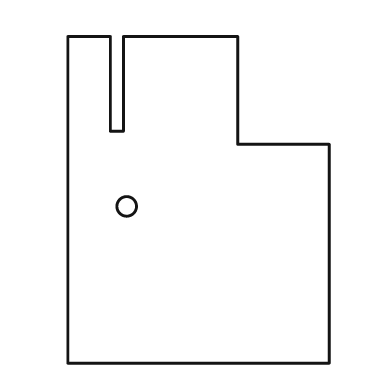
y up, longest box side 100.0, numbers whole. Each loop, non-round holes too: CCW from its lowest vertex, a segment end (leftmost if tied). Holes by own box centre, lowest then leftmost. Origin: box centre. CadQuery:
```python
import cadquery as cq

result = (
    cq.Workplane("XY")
    .moveTo(-40.0, -50.0)
    .lineTo(40.0, -50.0)
    .lineTo(40.0, 17.0)
    .lineTo(12.0, 17.0)
    .lineTo(12.0, 50.0)
    .lineTo(-23.0, 50.0)
    .lineTo(-23.0, 21.0)
    .lineTo(-27.0, 21.0)
    .lineTo(-27.0, 50.0)
    .lineTo(-40.0, 50.0)
    .close()
    .moveTo(-22.0, -2.0)
    .circle(3.0)
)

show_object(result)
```